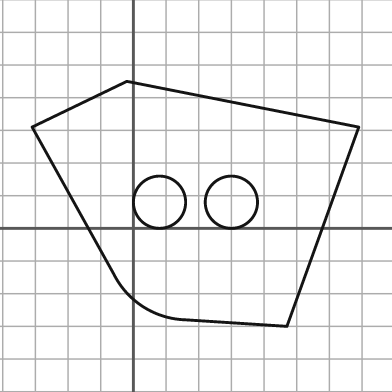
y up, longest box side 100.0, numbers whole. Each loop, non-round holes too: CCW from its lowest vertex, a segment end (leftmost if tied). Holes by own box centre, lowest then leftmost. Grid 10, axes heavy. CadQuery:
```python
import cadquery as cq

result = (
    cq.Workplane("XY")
    .moveTo(47.0, -30.0)
    .lineTo(69.0, 31.0)
    .lineTo(-2.0, 45.0)
    .lineTo(-31.0, 31.0)
    .lineTo(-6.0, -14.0)
    .threePointArc((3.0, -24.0), (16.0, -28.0))
    .close()
    .moveTo(8.0, 8.0)
    .circle(8.0)
    .moveTo(30.0, 8.0)
    .circle(8.0)
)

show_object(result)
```